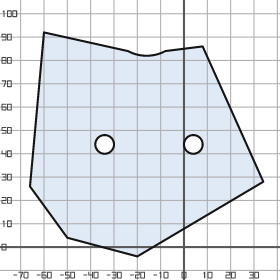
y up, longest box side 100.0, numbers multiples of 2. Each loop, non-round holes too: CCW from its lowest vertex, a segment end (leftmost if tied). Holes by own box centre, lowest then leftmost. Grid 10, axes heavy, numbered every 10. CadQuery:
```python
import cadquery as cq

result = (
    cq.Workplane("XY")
    .moveTo(-20.0, -4.0)
    .lineTo(34.0, 28.0)
    .lineTo(8.0, 86.0)
    .lineTo(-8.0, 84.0)
    .threePointArc((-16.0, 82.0), (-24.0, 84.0))
    .lineTo(-60.0, 92.0)
    .lineTo(-66.0, 26.0)
    .lineTo(-50.0, 4.0)
    .close()
    .moveTo(-34.0, 44.0)
    .circle(4.0)
    .moveTo(4.0, 44.0)
    .circle(4.0)
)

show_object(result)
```